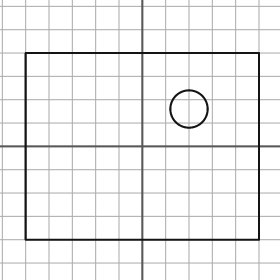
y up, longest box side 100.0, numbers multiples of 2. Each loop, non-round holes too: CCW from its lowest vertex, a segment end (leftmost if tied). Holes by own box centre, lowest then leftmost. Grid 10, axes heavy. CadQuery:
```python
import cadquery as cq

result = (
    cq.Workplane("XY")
    .moveTo(-50.0, -40.0)
    .lineTo(50.0, -40.0)
    .lineTo(50.0, 40.0)
    .lineTo(-50.0, 40.0)
    .close()
    .moveTo(20.0, 16.0)
    .circle(8.0)
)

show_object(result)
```